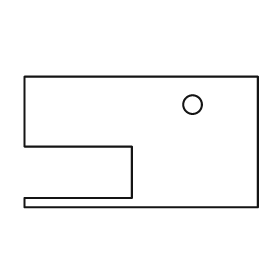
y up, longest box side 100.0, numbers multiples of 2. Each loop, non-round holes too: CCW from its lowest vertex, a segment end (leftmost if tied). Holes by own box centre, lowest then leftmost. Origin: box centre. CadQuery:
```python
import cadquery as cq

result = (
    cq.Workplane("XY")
    .moveTo(-50.0, -28.0)
    .lineTo(50.0, -28.0)
    .lineTo(50.0, 28.0)
    .lineTo(-50.0, 28.0)
    .lineTo(-50.0, -2.0)
    .lineTo(-4.0, -2.0)
    .lineTo(-4.0, -24.0)
    .lineTo(-50.0, -24.0)
    .close()
    .moveTo(22.0, 16.0)
    .circle(4.0)
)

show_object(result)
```